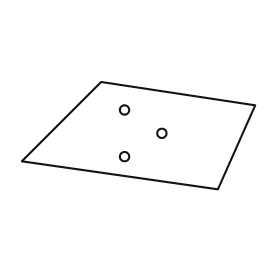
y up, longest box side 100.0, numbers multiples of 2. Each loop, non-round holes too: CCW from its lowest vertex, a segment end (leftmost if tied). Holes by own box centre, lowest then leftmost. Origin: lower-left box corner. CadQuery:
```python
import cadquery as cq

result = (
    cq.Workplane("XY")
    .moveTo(84.0, 0.0)
    .lineTo(100.0, 36.0)
    .lineTo(34.0, 46.0)
    .lineTo(0.0, 12.0)
    .close()
    .moveTo(44.0, 14.0)
    .circle(2.0)
    .moveTo(60.0, 24.0)
    .circle(2.0)
    .moveTo(44.0, 34.0)
    .circle(2.0)
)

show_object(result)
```